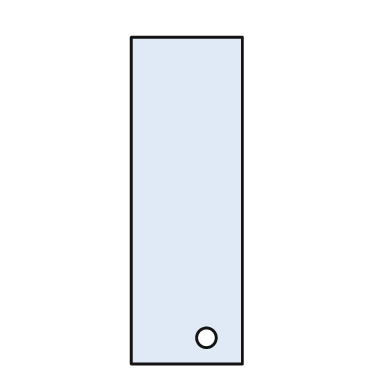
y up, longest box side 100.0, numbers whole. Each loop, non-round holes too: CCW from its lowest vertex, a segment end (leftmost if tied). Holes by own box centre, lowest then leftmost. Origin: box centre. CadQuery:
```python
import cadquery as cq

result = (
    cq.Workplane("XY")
    .moveTo(-17.0, -50.0)
    .lineTo(17.0, -50.0)
    .lineTo(17.0, 50.0)
    .lineTo(-17.0, 50.0)
    .close()
    .moveTo(6.0, -42.0)
    .circle(3.0)
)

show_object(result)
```